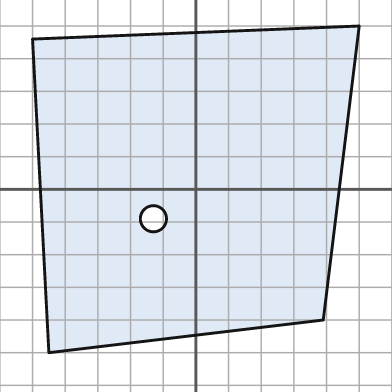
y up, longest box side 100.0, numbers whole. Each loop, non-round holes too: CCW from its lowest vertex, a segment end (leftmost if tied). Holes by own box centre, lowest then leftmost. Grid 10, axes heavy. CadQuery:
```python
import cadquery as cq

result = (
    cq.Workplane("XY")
    .moveTo(-45.0, -50.0)
    .lineTo(39.0, -40.0)
    .lineTo(50.0, 50.0)
    .lineTo(-50.0, 46.0)
    .close()
    .moveTo(-13.0, -9.0)
    .circle(4.0)
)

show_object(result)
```